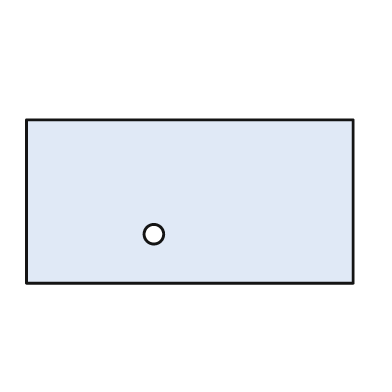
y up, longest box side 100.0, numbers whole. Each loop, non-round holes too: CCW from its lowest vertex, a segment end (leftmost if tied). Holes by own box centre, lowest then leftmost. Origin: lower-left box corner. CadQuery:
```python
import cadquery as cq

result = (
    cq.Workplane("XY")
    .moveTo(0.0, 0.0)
    .lineTo(100.0, 0.0)
    .lineTo(100.0, 50.0)
    .lineTo(0.0, 50.0)
    .close()
    .moveTo(39.0, 15.0)
    .circle(3.0)
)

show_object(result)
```